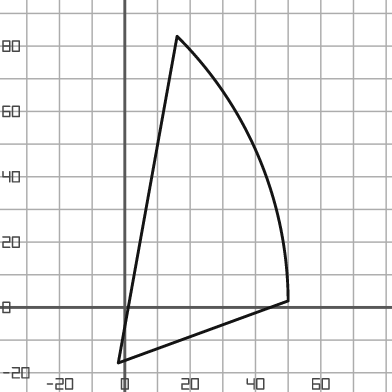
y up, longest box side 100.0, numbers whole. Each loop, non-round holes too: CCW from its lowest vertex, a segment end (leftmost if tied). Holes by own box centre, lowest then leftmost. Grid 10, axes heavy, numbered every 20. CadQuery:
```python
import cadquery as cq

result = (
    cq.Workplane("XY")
    .moveTo(-2.0, -17.0)
    .lineTo(50.0, 2.0)
    .threePointArc((41.0, 46.0), (16.0, 83.0))
    .close()
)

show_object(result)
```